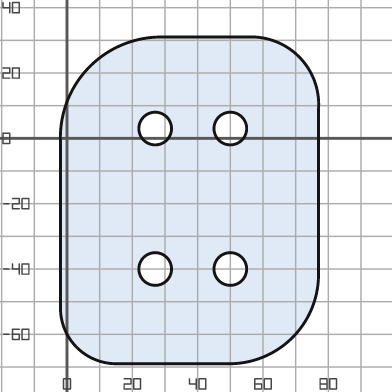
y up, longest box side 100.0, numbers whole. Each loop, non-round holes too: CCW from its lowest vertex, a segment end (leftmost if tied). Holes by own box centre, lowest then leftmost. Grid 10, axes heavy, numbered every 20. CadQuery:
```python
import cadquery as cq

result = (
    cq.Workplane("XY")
    .moveTo(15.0, -69.0)
    .lineTo(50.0, -69.0)
    .threePointArc((69.0, -61.0), (77.0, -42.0))
    .lineTo(77.0, 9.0)
    .threePointArc((71.0, 25.0), (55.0, 31.0))
    .lineTo(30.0, 31.0)
    .threePointArc((7.0, 22.0), (-2.0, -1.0))
    .lineTo(-2.0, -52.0)
    .threePointArc((3.0, -64.0), (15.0, -69.0))
    .close()
    .moveTo(27.0, -40.0)
    .circle(5.0)
    .moveTo(50.0, -40.0)
    .circle(5.0)
    .moveTo(27.0, 3.0)
    .circle(5.0)
    .moveTo(50.0, 3.0)
    .circle(5.0)
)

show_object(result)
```